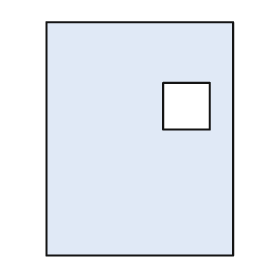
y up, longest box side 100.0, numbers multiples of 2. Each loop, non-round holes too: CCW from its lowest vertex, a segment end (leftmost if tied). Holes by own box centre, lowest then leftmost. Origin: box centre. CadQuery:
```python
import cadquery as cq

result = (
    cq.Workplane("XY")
    .moveTo(-40.0, -50.0)
    .lineTo(40.0, -50.0)
    .lineTo(40.0, 50.0)
    .lineTo(-40.0, 50.0)
    .close()
    .moveTo(10.0, 4.0)
    .lineTo(30.0, 4.0)
    .lineTo(30.0, 24.0)
    .lineTo(10.0, 24.0)
    .close()
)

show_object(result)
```